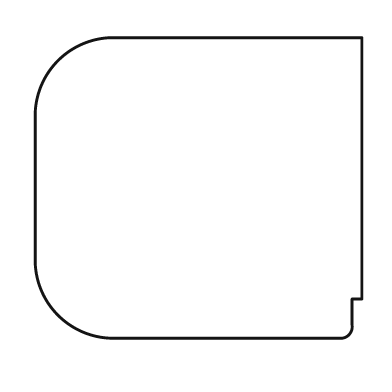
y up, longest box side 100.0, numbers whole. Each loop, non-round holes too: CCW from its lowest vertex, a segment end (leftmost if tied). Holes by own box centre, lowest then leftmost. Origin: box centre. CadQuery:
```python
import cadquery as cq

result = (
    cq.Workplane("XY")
    .moveTo(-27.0, -46.0)
    .lineTo(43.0, -46.0)
    .threePointArc((46.0, -45.0), (47.0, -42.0))
    .lineTo(47.0, -34.0)
    .lineTo(50.0, -34.0)
    .lineTo(50.0, 46.0)
    .lineTo(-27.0, 46.0)
    .threePointArc((-43.0, 39.0), (-50.0, 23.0))
    .lineTo(-50.0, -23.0)
    .threePointArc((-43.0, -39.0), (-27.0, -46.0))
    .close()
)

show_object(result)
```